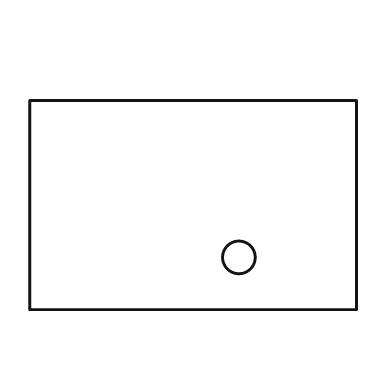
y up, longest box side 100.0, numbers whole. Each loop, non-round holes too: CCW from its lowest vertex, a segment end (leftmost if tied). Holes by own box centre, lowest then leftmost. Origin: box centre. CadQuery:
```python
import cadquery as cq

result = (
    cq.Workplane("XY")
    .moveTo(-50.0, -32.0)
    .lineTo(50.0, -32.0)
    .lineTo(50.0, 32.0)
    .lineTo(-50.0, 32.0)
    .close()
    .moveTo(14.0, -16.0)
    .circle(5.0)
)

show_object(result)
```